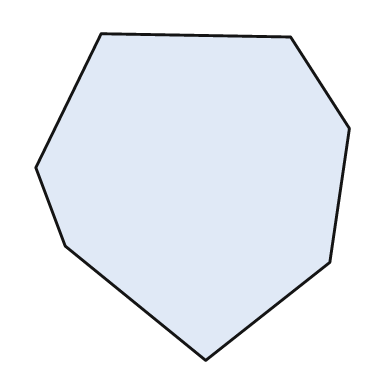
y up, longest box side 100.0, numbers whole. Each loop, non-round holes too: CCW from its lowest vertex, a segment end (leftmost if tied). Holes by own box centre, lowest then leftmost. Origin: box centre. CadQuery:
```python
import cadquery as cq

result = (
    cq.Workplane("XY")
    .moveTo(4.0, -50.0)
    .lineTo(42.0, -20.0)
    .lineTo(48.0, 21.0)
    .lineTo(30.0, 49.0)
    .lineTo(-28.0, 50.0)
    .lineTo(-48.0, 9.0)
    .lineTo(-39.0, -15.0)
    .close()
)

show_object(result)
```